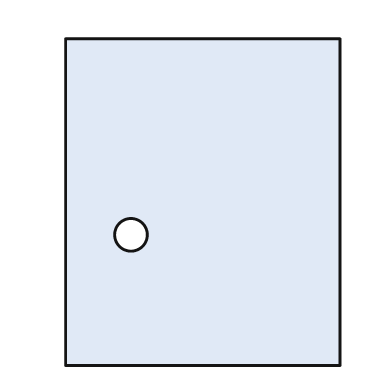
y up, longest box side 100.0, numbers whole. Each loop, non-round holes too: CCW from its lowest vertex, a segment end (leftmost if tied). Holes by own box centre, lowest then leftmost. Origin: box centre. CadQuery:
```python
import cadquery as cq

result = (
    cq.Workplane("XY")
    .moveTo(-42.0, -50.0)
    .lineTo(42.0, -50.0)
    .lineTo(42.0, 50.0)
    .lineTo(-42.0, 50.0)
    .close()
    .moveTo(-22.0, -10.0)
    .circle(5.0)
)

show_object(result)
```